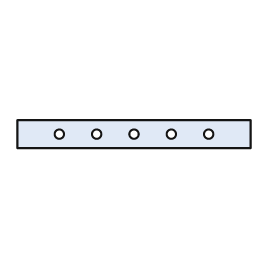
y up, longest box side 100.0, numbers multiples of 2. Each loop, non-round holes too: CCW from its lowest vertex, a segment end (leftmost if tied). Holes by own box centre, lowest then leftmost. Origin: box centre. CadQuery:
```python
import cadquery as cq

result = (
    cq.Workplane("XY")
    .moveTo(-50.0, -6.0)
    .lineTo(50.0, -6.0)
    .lineTo(50.0, 6.0)
    .lineTo(-50.0, 6.0)
    .close()
    .moveTo(-32.0, 0.0)
    .circle(2.0)
    .moveTo(-16.0, 0.0)
    .circle(2.0)
    .moveTo(0.0, 0.0)
    .circle(2.0)
    .moveTo(16.0, 0.0)
    .circle(2.0)
    .moveTo(32.0, 0.0)
    .circle(2.0)
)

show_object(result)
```